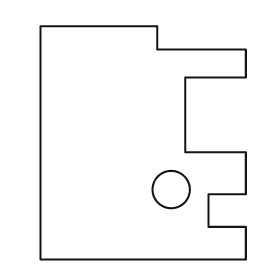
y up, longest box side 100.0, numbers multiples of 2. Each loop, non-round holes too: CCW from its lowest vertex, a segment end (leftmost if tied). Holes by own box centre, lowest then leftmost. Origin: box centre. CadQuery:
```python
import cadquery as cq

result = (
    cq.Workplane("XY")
    .moveTo(-44.0, -50.0)
    .lineTo(44.0, -50.0)
    .lineTo(44.0, -36.0)
    .lineTo(28.0, -36.0)
    .lineTo(28.0, -22.0)
    .lineTo(44.0, -22.0)
    .lineTo(44.0, -4.0)
    .lineTo(18.0, -4.0)
    .lineTo(18.0, 28.0)
    .lineTo(44.0, 28.0)
    .lineTo(44.0, 40.0)
    .lineTo(6.0, 40.0)
    .lineTo(6.0, 50.0)
    .lineTo(-44.0, 50.0)
    .close()
    .moveTo(12.0, -20.0)
    .circle(8.0)
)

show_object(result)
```